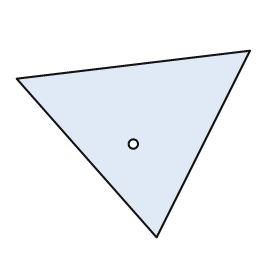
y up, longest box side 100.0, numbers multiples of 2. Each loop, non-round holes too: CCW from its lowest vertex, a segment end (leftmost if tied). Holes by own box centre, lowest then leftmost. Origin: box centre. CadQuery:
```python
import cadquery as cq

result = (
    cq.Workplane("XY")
    .moveTo(10.0, -40.0)
    .lineTo(50.0, 40.0)
    .lineTo(-50.0, 28.0)
    .close()
    .moveTo(0.0, 0.0)
    .circle(2.0)
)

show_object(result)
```